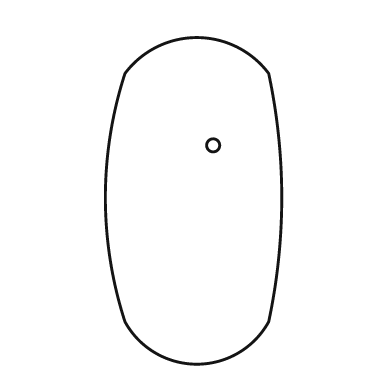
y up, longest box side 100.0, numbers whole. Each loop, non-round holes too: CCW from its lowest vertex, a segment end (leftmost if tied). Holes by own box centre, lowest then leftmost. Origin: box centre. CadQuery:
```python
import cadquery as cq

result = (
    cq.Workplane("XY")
    .moveTo(-21.0, -37.0)
    .threePointArc((1.0, -50.0), (23.0, -37.0))
    .threePointArc((27.0, 1.0), (23.0, 39.0))
    .threePointArc((1.0, 50.0), (-21.0, 39.0))
    .threePointArc((-27.0, 1.0), (-21.0, -37.0))
    .close()
    .moveTo(6.0, 17.0)
    .circle(2.0)
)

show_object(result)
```